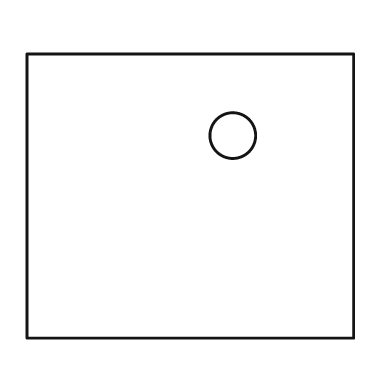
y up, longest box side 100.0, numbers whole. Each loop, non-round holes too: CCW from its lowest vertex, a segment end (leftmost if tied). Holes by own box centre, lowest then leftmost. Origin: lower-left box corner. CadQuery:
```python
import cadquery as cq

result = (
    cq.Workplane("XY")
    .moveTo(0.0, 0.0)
    .lineTo(100.0, 0.0)
    .lineTo(100.0, 87.0)
    .lineTo(0.0, 87.0)
    .close()
    .moveTo(63.0, 62.0)
    .circle(7.0)
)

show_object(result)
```